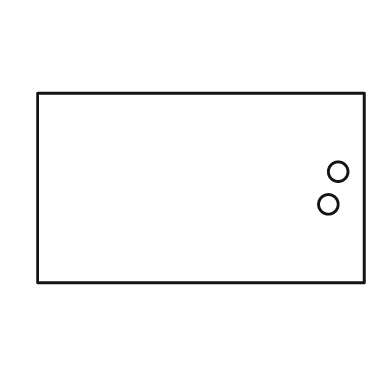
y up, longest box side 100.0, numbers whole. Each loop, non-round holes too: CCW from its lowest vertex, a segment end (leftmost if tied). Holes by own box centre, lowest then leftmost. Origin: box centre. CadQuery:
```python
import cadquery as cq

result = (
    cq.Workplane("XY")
    .moveTo(-50.0, -29.0)
    .lineTo(50.0, -29.0)
    .lineTo(50.0, 29.0)
    .lineTo(-50.0, 29.0)
    .close()
    .moveTo(39.0, -5.0)
    .circle(3.0)
    .moveTo(42.0, 5.0)
    .circle(3.0)
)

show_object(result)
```